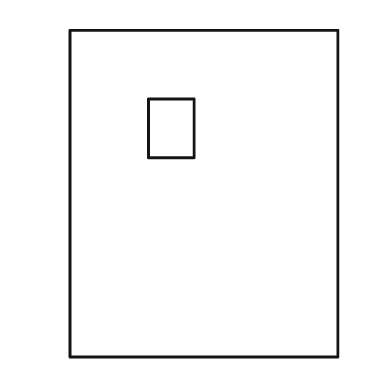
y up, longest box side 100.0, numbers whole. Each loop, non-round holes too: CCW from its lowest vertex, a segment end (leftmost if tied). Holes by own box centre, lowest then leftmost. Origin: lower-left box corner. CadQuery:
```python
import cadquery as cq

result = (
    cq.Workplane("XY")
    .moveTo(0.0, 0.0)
    .lineTo(82.0, 0.0)
    .lineTo(82.0, 100.0)
    .lineTo(0.0, 100.0)
    .close()
    .moveTo(24.0, 61.0)
    .lineTo(38.0, 61.0)
    .lineTo(38.0, 79.0)
    .lineTo(24.0, 79.0)
    .close()
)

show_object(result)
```